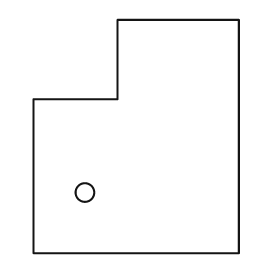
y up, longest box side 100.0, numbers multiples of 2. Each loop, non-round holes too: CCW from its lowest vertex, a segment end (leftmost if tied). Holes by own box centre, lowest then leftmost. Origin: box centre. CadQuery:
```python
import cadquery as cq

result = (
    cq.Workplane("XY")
    .moveTo(-44.0, -50.0)
    .lineTo(44.0, -50.0)
    .lineTo(44.0, 50.0)
    .lineTo(-8.0, 50.0)
    .lineTo(-8.0, 16.0)
    .lineTo(-44.0, 16.0)
    .close()
    .moveTo(-22.0, -24.0)
    .circle(4.0)
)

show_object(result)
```